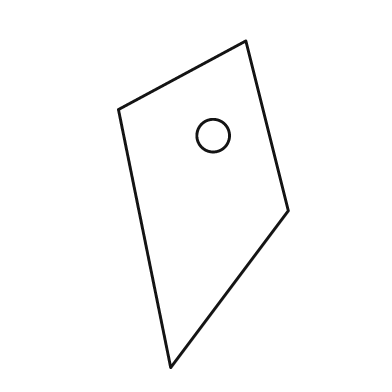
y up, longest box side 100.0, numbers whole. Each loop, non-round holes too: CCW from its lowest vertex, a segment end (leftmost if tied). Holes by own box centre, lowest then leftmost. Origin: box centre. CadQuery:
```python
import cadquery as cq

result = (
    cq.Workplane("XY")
    .moveTo(-10.0, -50.0)
    .lineTo(26.0, -2.0)
    .lineTo(13.0, 50.0)
    .lineTo(-26.0, 29.0)
    .close()
    .moveTo(3.0, 21.0)
    .circle(5.0)
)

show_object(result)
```